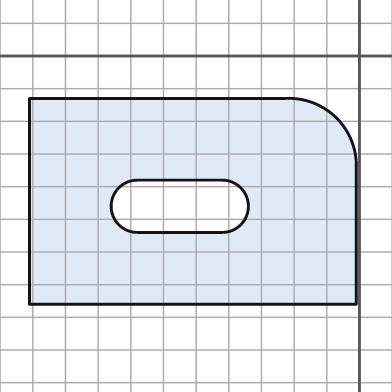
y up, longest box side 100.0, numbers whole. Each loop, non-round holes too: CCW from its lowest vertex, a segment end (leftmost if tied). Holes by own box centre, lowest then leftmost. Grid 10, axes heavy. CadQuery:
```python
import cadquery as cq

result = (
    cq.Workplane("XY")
    .moveTo(-101.0, -76.0)
    .lineTo(-1.0, -76.0)
    .lineTo(-1.0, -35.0)
    .threePointArc((-7.0, -19.0), (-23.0, -13.0))
    .lineTo(-101.0, -13.0)
    .close()
    .moveTo(-68.0, -54.0)
    .lineTo(-42.0, -54.0)
    .threePointArc((-34.0, -46.0), (-42.0, -38.0))
    .lineTo(-68.0, -38.0)
    .threePointArc((-76.0, -46.0), (-68.0, -54.0))
    .close()
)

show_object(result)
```